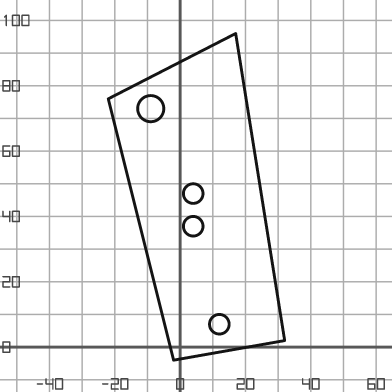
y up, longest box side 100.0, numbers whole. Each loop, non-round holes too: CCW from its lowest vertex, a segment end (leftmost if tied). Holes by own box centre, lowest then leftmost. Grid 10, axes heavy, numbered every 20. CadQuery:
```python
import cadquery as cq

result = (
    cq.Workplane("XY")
    .moveTo(-2.0, -4.0)
    .lineTo(32.0, 2.0)
    .lineTo(17.0, 96.0)
    .lineTo(-22.0, 76.0)
    .close()
    .moveTo(12.0, 7.0)
    .circle(3.0)
    .moveTo(4.0, 37.0)
    .circle(3.0)
    .moveTo(4.0, 47.0)
    .circle(3.0)
    .moveTo(-9.0, 73.0)
    .circle(4.0)
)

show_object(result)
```